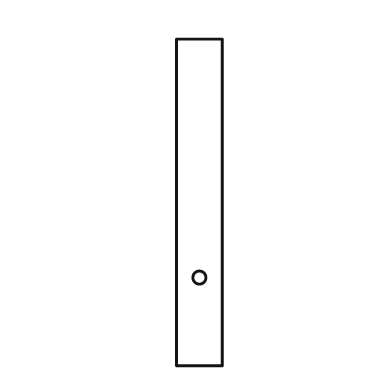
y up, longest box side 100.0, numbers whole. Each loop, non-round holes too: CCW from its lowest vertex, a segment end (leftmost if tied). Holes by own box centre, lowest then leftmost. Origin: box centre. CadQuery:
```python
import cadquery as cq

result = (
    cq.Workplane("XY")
    .moveTo(-7.0, -50.0)
    .lineTo(7.0, -50.0)
    .lineTo(7.0, 50.0)
    .lineTo(-7.0, 50.0)
    .close()
    .moveTo(0.0, -23.0)
    .circle(2.0)
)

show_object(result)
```